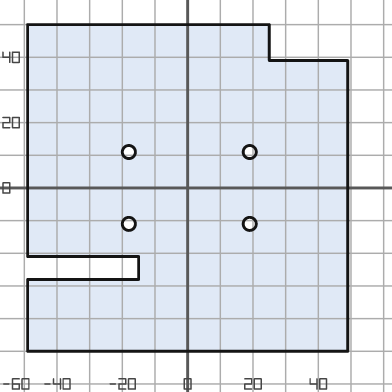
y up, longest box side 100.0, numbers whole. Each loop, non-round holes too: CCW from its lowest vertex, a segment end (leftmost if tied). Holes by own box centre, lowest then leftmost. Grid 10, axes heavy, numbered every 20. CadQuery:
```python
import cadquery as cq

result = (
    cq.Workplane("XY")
    .moveTo(-49.0, -50.0)
    .lineTo(49.0, -50.0)
    .lineTo(49.0, 39.0)
    .lineTo(25.0, 39.0)
    .lineTo(25.0, 50.0)
    .lineTo(-49.0, 50.0)
    .lineTo(-49.0, -21.0)
    .lineTo(-15.0, -21.0)
    .lineTo(-15.0, -28.0)
    .lineTo(-49.0, -28.0)
    .close()
    .moveTo(-18.0, -11.0)
    .circle(2.0)
    .moveTo(19.0, -11.0)
    .circle(2.0)
    .moveTo(-18.0, 11.0)
    .circle(2.0)
    .moveTo(19.0, 11.0)
    .circle(2.0)
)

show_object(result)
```